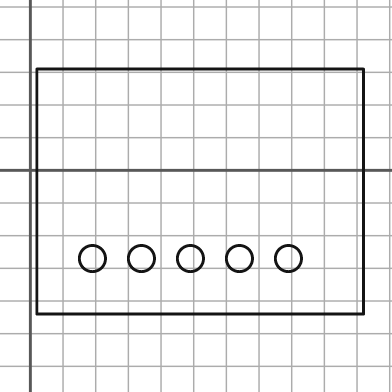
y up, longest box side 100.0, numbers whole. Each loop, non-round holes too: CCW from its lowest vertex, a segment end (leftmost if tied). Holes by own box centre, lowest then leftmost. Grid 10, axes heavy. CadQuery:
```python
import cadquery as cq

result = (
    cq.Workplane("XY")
    .moveTo(2.0, -44.0)
    .lineTo(102.0, -44.0)
    .lineTo(102.0, 31.0)
    .lineTo(2.0, 31.0)
    .close()
    .moveTo(19.0, -27.0)
    .circle(4.0)
    .moveTo(34.0, -27.0)
    .circle(4.0)
    .moveTo(49.0, -27.0)
    .circle(4.0)
    .moveTo(64.0, -27.0)
    .circle(4.0)
    .moveTo(79.0, -27.0)
    .circle(4.0)
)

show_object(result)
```